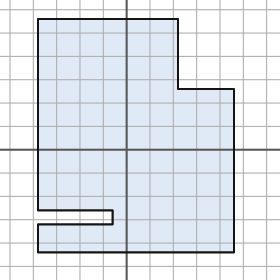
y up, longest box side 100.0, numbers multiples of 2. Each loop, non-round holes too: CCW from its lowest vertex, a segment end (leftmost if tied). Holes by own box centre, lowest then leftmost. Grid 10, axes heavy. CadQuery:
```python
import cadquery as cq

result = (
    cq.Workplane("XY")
    .moveTo(-38.0, -44.0)
    .lineTo(46.0, -44.0)
    .lineTo(46.0, 26.0)
    .lineTo(22.0, 26.0)
    .lineTo(22.0, 56.0)
    .lineTo(-38.0, 56.0)
    .lineTo(-38.0, -26.0)
    .lineTo(-6.0, -26.0)
    .lineTo(-6.0, -32.0)
    .lineTo(-38.0, -32.0)
    .close()
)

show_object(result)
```